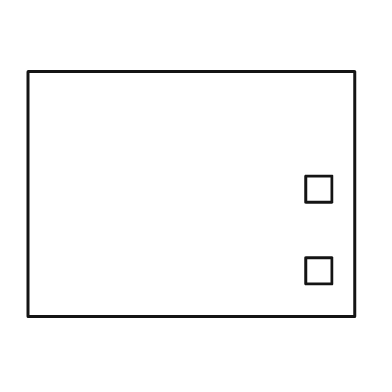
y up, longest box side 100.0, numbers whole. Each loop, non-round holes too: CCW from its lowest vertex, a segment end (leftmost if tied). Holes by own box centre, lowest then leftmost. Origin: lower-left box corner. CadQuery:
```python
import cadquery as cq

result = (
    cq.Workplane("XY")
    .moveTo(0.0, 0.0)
    .lineTo(100.0, 0.0)
    .lineTo(100.0, 75.0)
    .lineTo(0.0, 75.0)
    .close()
    .moveTo(85.0, 10.0)
    .lineTo(93.0, 10.0)
    .lineTo(93.0, 18.0)
    .lineTo(85.0, 18.0)
    .close()
    .moveTo(85.0, 35.0)
    .lineTo(93.0, 35.0)
    .lineTo(93.0, 43.0)
    .lineTo(85.0, 43.0)
    .close()
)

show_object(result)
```